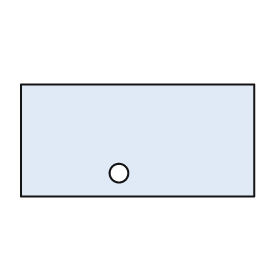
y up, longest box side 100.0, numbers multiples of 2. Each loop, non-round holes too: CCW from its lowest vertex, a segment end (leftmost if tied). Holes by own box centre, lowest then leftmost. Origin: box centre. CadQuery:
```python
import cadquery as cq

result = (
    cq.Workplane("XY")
    .moveTo(-50.0, -24.0)
    .lineTo(50.0, -24.0)
    .lineTo(50.0, 24.0)
    .lineTo(-50.0, 24.0)
    .close()
    .moveTo(-8.0, -14.0)
    .circle(4.0)
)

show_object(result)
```